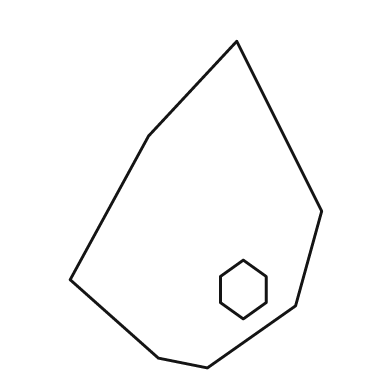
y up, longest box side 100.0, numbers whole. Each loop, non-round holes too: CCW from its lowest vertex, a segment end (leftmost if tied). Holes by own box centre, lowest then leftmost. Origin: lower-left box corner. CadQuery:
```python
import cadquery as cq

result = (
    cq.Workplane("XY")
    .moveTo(42.0, 0.0)
    .lineTo(69.0, 19.0)
    .lineTo(77.0, 48.0)
    .lineTo(51.0, 100.0)
    .lineTo(24.0, 71.0)
    .lineTo(0.0, 27.0)
    .lineTo(27.0, 3.0)
    .close()
    .moveTo(53.0, 15.0)
    .lineTo(60.0, 20.0)
    .lineTo(60.0, 28.0)
    .lineTo(53.0, 33.0)
    .lineTo(46.0, 28.0)
    .lineTo(46.0, 20.0)
    .close()
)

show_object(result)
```